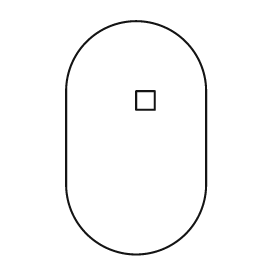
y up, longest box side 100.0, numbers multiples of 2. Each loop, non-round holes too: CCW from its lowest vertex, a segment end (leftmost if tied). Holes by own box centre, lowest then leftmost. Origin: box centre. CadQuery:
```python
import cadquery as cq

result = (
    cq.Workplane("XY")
    .moveTo(-30.0, -20.0)
    .threePointArc((0.0, -50.0), (30.0, -20.0))
    .lineTo(30.0, 20.0)
    .threePointArc((0.0, 50.0), (-30.0, 20.0))
    .close()
    .moveTo(0.0, 12.0)
    .lineTo(8.0, 12.0)
    .lineTo(8.0, 20.0)
    .lineTo(0.0, 20.0)
    .close()
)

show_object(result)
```